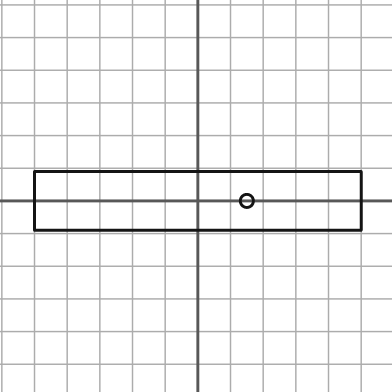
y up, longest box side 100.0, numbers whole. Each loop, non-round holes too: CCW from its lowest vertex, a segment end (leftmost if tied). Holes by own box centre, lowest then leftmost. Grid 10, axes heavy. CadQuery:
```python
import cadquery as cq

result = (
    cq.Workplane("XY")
    .moveTo(-50.0, -9.0)
    .lineTo(50.0, -9.0)
    .lineTo(50.0, 9.0)
    .lineTo(-50.0, 9.0)
    .close()
    .moveTo(15.0, 0.0)
    .circle(2.0)
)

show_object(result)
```